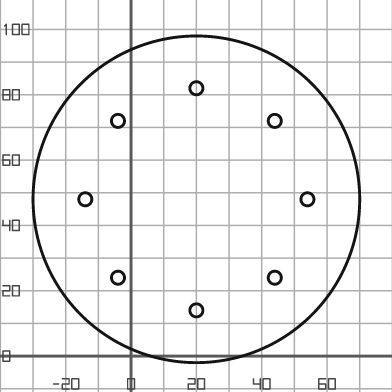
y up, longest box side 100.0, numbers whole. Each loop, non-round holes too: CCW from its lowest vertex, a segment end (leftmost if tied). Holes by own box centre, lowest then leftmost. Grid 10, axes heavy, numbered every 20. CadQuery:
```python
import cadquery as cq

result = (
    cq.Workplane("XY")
    .moveTo(20.0, 48.0)
    .circle(50.0)
    .moveTo(20.0, 14.0)
    .circle(2.0)
    .moveTo(-4.0, 24.0)
    .circle(2.0)
    .moveTo(44.0, 24.0)
    .circle(2.0)
    .moveTo(-14.0, 48.0)
    .circle(2.0)
    .moveTo(54.0, 48.0)
    .circle(2.0)
    .moveTo(-4.0, 72.0)
    .circle(2.0)
    .moveTo(44.0, 72.0)
    .circle(2.0)
    .moveTo(20.0, 82.0)
    .circle(2.0)
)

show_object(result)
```